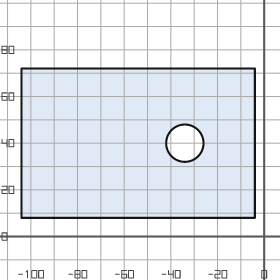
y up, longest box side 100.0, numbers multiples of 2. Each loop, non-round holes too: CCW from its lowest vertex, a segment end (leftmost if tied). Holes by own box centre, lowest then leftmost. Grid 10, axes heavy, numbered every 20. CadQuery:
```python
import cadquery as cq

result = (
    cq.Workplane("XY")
    .moveTo(-104.0, 8.0)
    .lineTo(-4.0, 8.0)
    .lineTo(-4.0, 72.0)
    .lineTo(-104.0, 72.0)
    .close()
    .moveTo(-34.0, 40.0)
    .circle(8.0)
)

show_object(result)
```